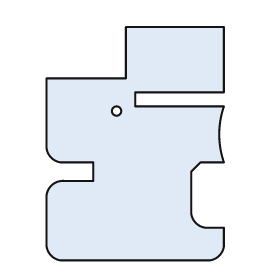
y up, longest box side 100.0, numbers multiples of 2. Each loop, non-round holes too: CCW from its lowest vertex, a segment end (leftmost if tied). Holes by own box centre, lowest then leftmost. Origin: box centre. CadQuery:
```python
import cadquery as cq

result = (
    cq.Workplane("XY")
    .moveTo(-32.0, -50.0)
    .lineTo(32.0, -50.0)
    .threePointArc((36.0, -48.0), (38.0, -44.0))
    .lineTo(38.0, -36.0)
    .lineTo(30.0, -36.0)
    .threePointArc((26.0, -34.0), (24.0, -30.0))
    .lineTo(24.0, -12.0)
    .lineTo(28.0, -8.0)
    .lineTo(38.0, -8.0)
    .threePointArc((36.0, 4.0), (38.0, 16.0))
    .lineTo(0.0, 16.0)
    .lineTo(0.0, 22.0)
    .lineTo(38.0, 22.0)
    .lineTo(38.0, 50.0)
    .lineTo(-4.0, 50.0)
    .lineTo(-4.0, 28.0)
    .lineTo(-38.0, 28.0)
    .lineTo(-38.0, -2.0)
    .threePointArc((-36.0, -6.0), (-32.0, -8.0))
    .lineTo(-18.0, -8.0)
    .lineTo(-18.0, -16.0)
    .lineTo(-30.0, -16.0)
    .threePointArc((-36.0, -18.0), (-38.0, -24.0))
    .lineTo(-38.0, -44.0)
    .threePointArc((-36.0, -48.0), (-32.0, -50.0))
    .close()
    .moveTo(-8.0, 14.0)
    .circle(2.0)
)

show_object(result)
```